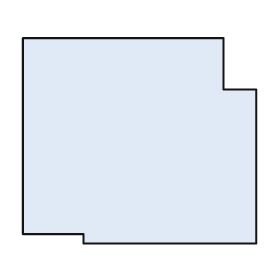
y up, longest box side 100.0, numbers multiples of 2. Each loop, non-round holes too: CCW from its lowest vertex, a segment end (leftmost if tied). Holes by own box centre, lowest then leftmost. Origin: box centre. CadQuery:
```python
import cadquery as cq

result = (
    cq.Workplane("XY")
    .moveTo(-24.0, -44.0)
    .lineTo(50.0, -44.0)
    .lineTo(50.0, 22.0)
    .lineTo(36.0, 22.0)
    .lineTo(36.0, 44.0)
    .lineTo(-50.0, 44.0)
    .lineTo(-50.0, -40.0)
    .lineTo(-24.0, -40.0)
    .close()
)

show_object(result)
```